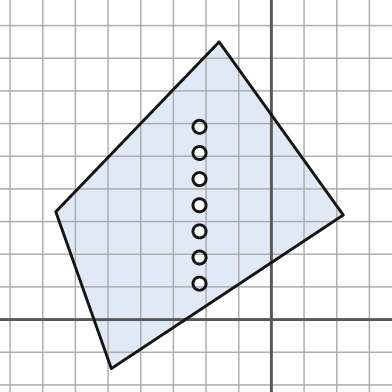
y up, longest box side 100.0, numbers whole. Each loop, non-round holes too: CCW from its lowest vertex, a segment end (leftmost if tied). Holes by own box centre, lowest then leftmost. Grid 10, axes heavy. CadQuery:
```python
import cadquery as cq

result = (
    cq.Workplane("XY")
    .moveTo(-49.0, -15.0)
    .lineTo(22.0, 32.0)
    .lineTo(-16.0, 85.0)
    .lineTo(-66.0, 33.0)
    .close()
    .moveTo(-22.0, 11.0)
    .circle(2.0)
    .moveTo(-22.0, 19.0)
    .circle(2.0)
    .moveTo(-22.0, 27.0)
    .circle(2.0)
    .moveTo(-22.0, 35.0)
    .circle(2.0)
    .moveTo(-22.0, 43.0)
    .circle(2.0)
    .moveTo(-22.0, 51.0)
    .circle(2.0)
    .moveTo(-22.0, 59.0)
    .circle(2.0)
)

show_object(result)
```